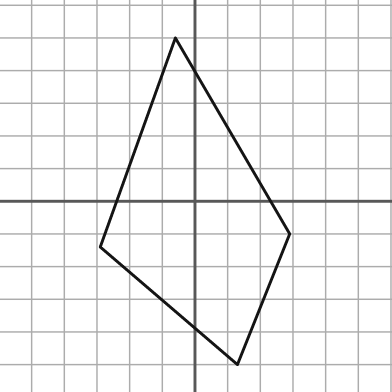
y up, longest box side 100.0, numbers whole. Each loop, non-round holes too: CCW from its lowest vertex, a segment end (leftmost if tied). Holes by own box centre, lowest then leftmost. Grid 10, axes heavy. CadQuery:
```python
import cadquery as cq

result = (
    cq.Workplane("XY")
    .moveTo(13.0, -50.0)
    .lineTo(29.0, -10.0)
    .lineTo(-6.0, 50.0)
    .lineTo(-29.0, -14.0)
    .close()
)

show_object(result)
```